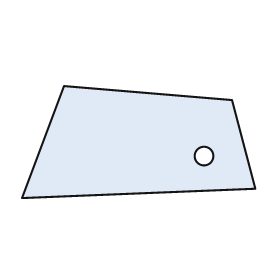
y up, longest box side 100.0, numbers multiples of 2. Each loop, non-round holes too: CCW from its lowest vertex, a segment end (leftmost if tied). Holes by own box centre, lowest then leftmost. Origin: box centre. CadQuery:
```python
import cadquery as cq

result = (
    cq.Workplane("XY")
    .moveTo(-50.0, -24.0)
    .lineTo(50.0, -20.0)
    .lineTo(40.0, 18.0)
    .lineTo(-32.0, 24.0)
    .close()
    .moveTo(28.0, -6.0)
    .circle(4.0)
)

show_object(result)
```